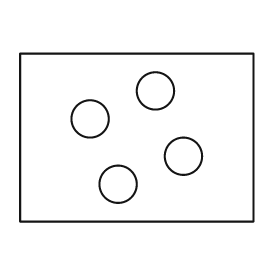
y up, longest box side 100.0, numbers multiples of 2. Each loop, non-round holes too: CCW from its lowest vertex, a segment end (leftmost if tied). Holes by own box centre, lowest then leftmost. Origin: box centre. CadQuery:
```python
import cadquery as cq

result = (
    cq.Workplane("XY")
    .moveTo(-50.0, -36.0)
    .lineTo(50.0, -36.0)
    .lineTo(50.0, 36.0)
    .lineTo(-50.0, 36.0)
    .close()
    .moveTo(-8.0, -20.0)
    .circle(8.0)
    .moveTo(20.0, -8.0)
    .circle(8.0)
    .moveTo(-20.0, 8.0)
    .circle(8.0)
    .moveTo(8.0, 20.0)
    .circle(8.0)
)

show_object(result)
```